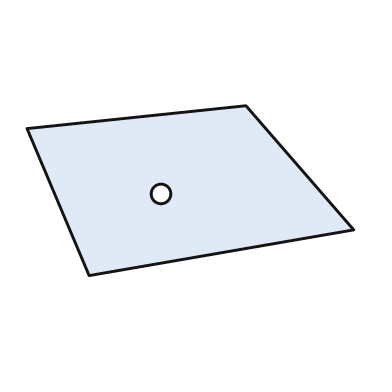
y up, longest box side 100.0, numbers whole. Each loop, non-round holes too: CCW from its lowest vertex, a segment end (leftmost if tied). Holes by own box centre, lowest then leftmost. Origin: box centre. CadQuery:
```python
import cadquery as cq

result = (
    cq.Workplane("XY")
    .moveTo(-31.0, -26.0)
    .lineTo(50.0, -12.0)
    .lineTo(17.0, 26.0)
    .lineTo(-50.0, 19.0)
    .close()
    .moveTo(-9.0, -1.0)
    .circle(3.0)
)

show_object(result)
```